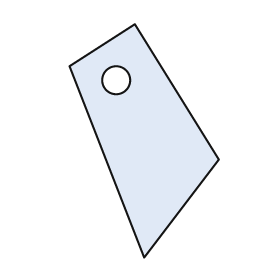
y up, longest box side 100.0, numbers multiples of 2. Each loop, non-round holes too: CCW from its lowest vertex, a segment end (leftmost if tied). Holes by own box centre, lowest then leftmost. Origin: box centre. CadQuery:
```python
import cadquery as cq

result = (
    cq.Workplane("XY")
    .moveTo(0.0, -50.0)
    .lineTo(32.0, -8.0)
    .lineTo(-4.0, 50.0)
    .lineTo(-32.0, 32.0)
    .close()
    .moveTo(-12.0, 26.0)
    .circle(6.0)
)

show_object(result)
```